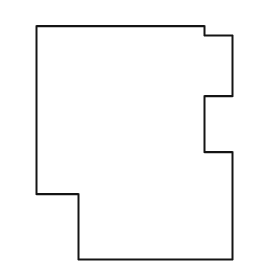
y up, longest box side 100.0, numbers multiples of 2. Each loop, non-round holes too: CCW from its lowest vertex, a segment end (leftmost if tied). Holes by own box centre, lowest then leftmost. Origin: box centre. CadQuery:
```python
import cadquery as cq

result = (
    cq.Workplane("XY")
    .moveTo(-24.0, -50.0)
    .lineTo(42.0, -50.0)
    .lineTo(42.0, -4.0)
    .lineTo(30.0, -4.0)
    .lineTo(30.0, 20.0)
    .lineTo(42.0, 20.0)
    .lineTo(42.0, 46.0)
    .lineTo(30.0, 46.0)
    .lineTo(30.0, 50.0)
    .lineTo(-42.0, 50.0)
    .lineTo(-42.0, -22.0)
    .lineTo(-24.0, -22.0)
    .close()
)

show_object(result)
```